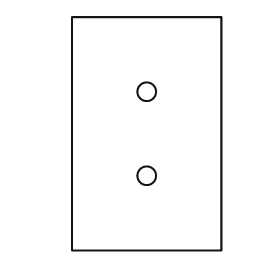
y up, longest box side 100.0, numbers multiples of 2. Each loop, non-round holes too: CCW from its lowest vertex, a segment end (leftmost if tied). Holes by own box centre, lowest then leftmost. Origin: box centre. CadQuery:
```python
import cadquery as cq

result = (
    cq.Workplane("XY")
    .moveTo(-32.0, -50.0)
    .lineTo(32.0, -50.0)
    .lineTo(32.0, 50.0)
    .lineTo(-32.0, 50.0)
    .close()
    .moveTo(0.0, -18.0)
    .circle(4.0)
    .moveTo(0.0, 18.0)
    .circle(4.0)
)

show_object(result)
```